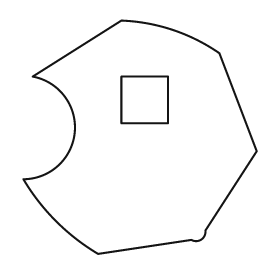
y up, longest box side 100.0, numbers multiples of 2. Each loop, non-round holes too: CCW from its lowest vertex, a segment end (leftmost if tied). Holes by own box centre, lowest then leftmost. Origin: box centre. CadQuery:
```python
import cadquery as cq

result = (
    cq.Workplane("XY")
    .moveTo(-18.0, -50.0)
    .lineTo(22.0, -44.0)
    .threePointArc((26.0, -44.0), (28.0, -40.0))
    .lineTo(50.0, -6.0)
    .lineTo(34.0, 36.0)
    .threePointArc((14.0, 46.0), (-8.0, 50.0))
    .lineTo(-46.0, 26.0)
    .threePointArc((-28.0, 2.0), (-50.0, -18.0))
    .threePointArc((-36.0, -36.0), (-18.0, -50.0))
    .close()
    .moveTo(-8.0, 6.0)
    .lineTo(12.0, 6.0)
    .lineTo(12.0, 26.0)
    .lineTo(-8.0, 26.0)
    .close()
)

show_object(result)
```